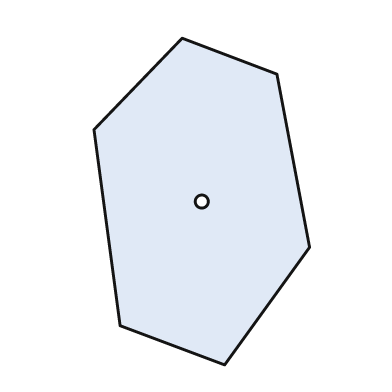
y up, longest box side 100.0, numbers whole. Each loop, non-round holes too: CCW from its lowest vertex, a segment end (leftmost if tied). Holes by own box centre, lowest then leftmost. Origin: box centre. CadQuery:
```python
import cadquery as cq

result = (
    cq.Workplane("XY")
    .moveTo(7.0, -50.0)
    .lineTo(33.0, -14.0)
    .lineTo(23.0, 39.0)
    .lineTo(-6.0, 50.0)
    .lineTo(-33.0, 22.0)
    .lineTo(-25.0, -38.0)
    .close()
    .moveTo(0.0, 0.0)
    .circle(2.0)
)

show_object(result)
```